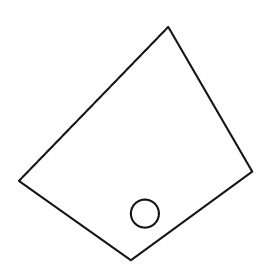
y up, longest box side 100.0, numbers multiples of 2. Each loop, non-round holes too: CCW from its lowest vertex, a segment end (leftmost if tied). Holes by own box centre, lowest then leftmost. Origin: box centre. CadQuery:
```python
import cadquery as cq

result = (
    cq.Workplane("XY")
    .moveTo(-2.0, -50.0)
    .lineTo(50.0, -12.0)
    .lineTo(14.0, 50.0)
    .lineTo(-50.0, -16.0)
    .close()
    .moveTo(4.0, -30.0)
    .circle(6.0)
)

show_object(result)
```